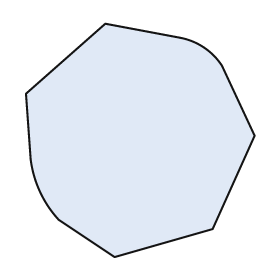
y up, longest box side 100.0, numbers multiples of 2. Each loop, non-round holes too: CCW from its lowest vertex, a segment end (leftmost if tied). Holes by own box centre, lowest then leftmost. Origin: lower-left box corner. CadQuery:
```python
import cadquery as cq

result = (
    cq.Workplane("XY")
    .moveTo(38.0, 0.0)
    .lineTo(80.0, 12.0)
    .lineTo(98.0, 52.0)
    .lineTo(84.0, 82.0)
    .threePointArc((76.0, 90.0), (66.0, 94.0))
    .lineTo(34.0, 100.0)
    .lineTo(0.0, 70.0)
    .lineTo(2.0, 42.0)
    .threePointArc((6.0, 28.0), (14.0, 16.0))
    .close()
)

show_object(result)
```